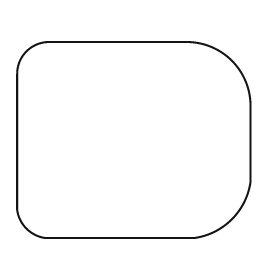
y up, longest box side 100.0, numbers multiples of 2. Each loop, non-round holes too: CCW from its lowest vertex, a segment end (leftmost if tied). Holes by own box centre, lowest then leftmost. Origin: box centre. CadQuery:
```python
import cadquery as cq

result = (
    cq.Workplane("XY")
    .moveTo(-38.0, -42.0)
    .lineTo(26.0, -42.0)
    .threePointArc((42.0, -34.0), (50.0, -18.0))
    .lineTo(50.0, 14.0)
    .threePointArc((42.0, 34.0), (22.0, 42.0))
    .lineTo(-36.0, 42.0)
    .threePointArc((-46.0, 38.0), (-50.0, 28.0))
    .lineTo(-50.0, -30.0)
    .threePointArc((-46.0, -38.0), (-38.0, -42.0))
    .close()
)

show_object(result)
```